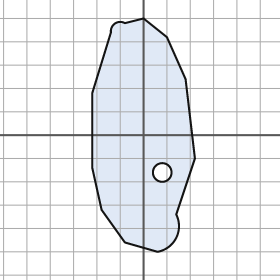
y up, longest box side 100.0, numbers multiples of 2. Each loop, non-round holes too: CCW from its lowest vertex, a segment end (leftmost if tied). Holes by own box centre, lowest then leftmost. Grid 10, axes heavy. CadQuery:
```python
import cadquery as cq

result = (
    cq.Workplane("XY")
    .moveTo(6.0, -50.0)
    .threePointArc((14.0, -44.0), (14.0, -34.0))
    .lineTo(22.0, -10.0)
    .lineTo(18.0, 24.0)
    .lineTo(10.0, 42.0)
    .lineTo(0.0, 50.0)
    .lineTo(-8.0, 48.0)
    .threePointArc((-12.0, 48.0), (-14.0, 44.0))
    .lineTo(-22.0, 18.0)
    .lineTo(-22.0, -14.0)
    .lineTo(-18.0, -32.0)
    .lineTo(-8.0, -46.0)
    .close()
    .moveTo(8.0, -16.0)
    .circle(4.0)
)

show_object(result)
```